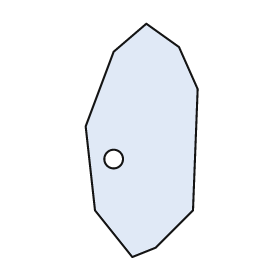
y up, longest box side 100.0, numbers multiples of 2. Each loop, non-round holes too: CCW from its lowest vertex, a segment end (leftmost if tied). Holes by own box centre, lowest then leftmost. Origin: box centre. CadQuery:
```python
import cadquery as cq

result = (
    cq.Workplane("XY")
    .moveTo(-4.0, -50.0)
    .lineTo(6.0, -46.0)
    .lineTo(22.0, -30.0)
    .lineTo(24.0, 22.0)
    .lineTo(16.0, 40.0)
    .lineTo(2.0, 50.0)
    .lineTo(-12.0, 38.0)
    .lineTo(-24.0, 6.0)
    .lineTo(-20.0, -30.0)
    .close()
    .moveTo(-12.0, -8.0)
    .circle(4.0)
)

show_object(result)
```